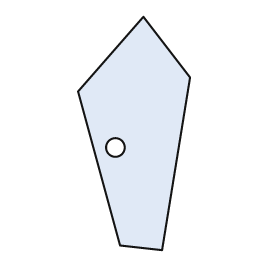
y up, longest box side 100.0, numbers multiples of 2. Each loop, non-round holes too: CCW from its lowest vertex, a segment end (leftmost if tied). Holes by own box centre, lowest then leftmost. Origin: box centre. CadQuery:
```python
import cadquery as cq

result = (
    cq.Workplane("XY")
    .moveTo(12.0, -50.0)
    .lineTo(24.0, 24.0)
    .lineTo(4.0, 50.0)
    .lineTo(-24.0, 18.0)
    .lineTo(-6.0, -48.0)
    .close()
    .moveTo(-8.0, -6.0)
    .circle(4.0)
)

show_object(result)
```